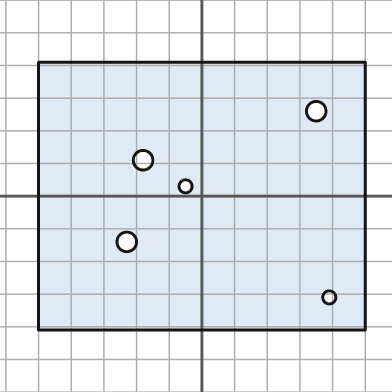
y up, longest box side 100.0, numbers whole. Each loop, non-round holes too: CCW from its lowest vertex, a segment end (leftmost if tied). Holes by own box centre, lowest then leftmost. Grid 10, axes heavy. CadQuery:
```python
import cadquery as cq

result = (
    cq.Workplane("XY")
    .moveTo(-50.0, -41.0)
    .lineTo(50.0, -41.0)
    .lineTo(50.0, 41.0)
    .lineTo(-50.0, 41.0)
    .close()
    .moveTo(39.0, -31.0)
    .circle(2.0)
    .moveTo(-23.0, -14.0)
    .circle(3.0)
    .moveTo(-5.0, 3.0)
    .circle(2.0)
    .moveTo(-18.0, 11.0)
    .circle(3.0)
    .moveTo(35.0, 26.0)
    .circle(3.0)
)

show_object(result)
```